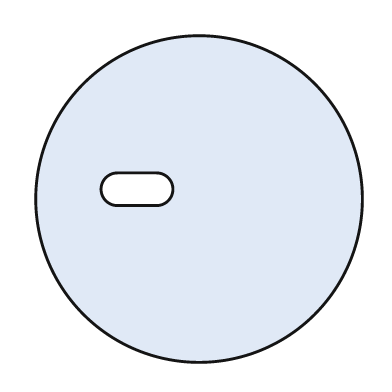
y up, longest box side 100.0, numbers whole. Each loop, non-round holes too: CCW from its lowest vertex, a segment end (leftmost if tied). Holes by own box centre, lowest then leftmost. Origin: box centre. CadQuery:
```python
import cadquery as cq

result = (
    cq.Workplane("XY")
    .moveTo(0.0, 0.0)
    .circle(50.0)
    .moveTo(-25.0, -2.0)
    .lineTo(-13.0, -2.0)
    .threePointArc((-8.0, 3.0), (-13.0, 8.0))
    .lineTo(-25.0, 8.0)
    .threePointArc((-30.0, 3.0), (-25.0, -2.0))
    .close()
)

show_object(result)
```